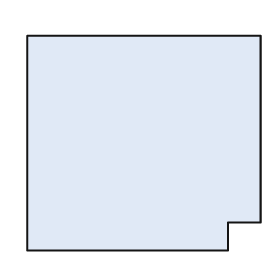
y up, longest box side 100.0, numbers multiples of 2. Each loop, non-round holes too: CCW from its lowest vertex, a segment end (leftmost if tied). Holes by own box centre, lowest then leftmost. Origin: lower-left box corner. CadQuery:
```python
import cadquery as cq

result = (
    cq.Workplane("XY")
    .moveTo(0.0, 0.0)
    .lineTo(86.0, 0.0)
    .lineTo(86.0, 12.0)
    .lineTo(100.0, 12.0)
    .lineTo(100.0, 92.0)
    .lineTo(0.0, 92.0)
    .close()
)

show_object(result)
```